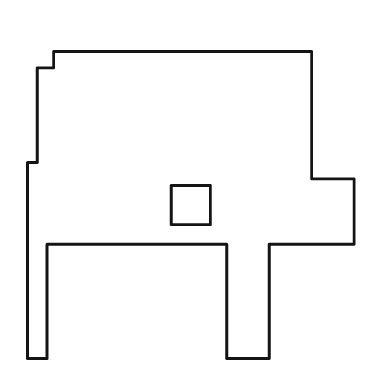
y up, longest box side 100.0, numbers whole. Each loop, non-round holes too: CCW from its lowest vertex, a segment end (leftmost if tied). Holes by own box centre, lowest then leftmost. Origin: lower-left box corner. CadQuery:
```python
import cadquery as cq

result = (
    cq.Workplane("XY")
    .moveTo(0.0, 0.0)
    .lineTo(6.0, 0.0)
    .lineTo(6.0, 35.0)
    .lineTo(61.0, 35.0)
    .lineTo(61.0, 0.0)
    .lineTo(74.0, 0.0)
    .lineTo(74.0, 35.0)
    .lineTo(100.0, 35.0)
    .lineTo(100.0, 55.0)
    .lineTo(87.0, 55.0)
    .lineTo(87.0, 94.0)
    .lineTo(8.0, 94.0)
    .lineTo(8.0, 89.0)
    .lineTo(3.0, 89.0)
    .lineTo(3.0, 60.0)
    .lineTo(0.0, 60.0)
    .close()
    .moveTo(44.0, 41.0)
    .lineTo(56.0, 41.0)
    .lineTo(56.0, 53.0)
    .lineTo(44.0, 53.0)
    .close()
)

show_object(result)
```